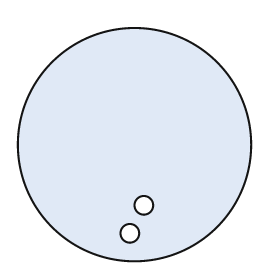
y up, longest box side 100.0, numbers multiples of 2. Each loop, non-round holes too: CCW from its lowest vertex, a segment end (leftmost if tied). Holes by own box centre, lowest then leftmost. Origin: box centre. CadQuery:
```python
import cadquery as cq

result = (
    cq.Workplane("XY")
    .moveTo(0.0, 0.0)
    .circle(50.0)
    .moveTo(-2.0, -38.0)
    .circle(4.0)
    .moveTo(4.0, -26.0)
    .circle(4.0)
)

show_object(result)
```